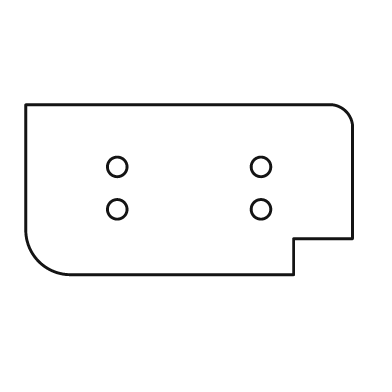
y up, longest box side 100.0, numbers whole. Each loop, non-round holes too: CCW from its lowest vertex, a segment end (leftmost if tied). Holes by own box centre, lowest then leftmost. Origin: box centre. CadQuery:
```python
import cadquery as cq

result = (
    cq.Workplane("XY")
    .moveTo(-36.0, -26.0)
    .lineTo(32.0, -26.0)
    .lineTo(32.0, -15.0)
    .lineTo(50.0, -15.0)
    .lineTo(50.0, 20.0)
    .threePointArc((48.0, 24.0), (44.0, 26.0))
    .lineTo(-50.0, 26.0)
    .lineTo(-50.0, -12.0)
    .threePointArc((-46.0, -22.0), (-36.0, -26.0))
    .close()
    .moveTo(-22.0, -6.0)
    .circle(3.0)
    .moveTo(22.0, -6.0)
    .circle(3.0)
    .moveTo(-22.0, 7.0)
    .circle(3.0)
    .moveTo(22.0, 7.0)
    .circle(3.0)
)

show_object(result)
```